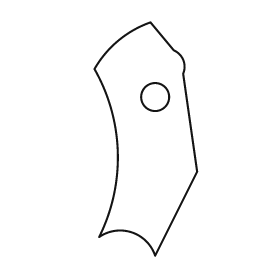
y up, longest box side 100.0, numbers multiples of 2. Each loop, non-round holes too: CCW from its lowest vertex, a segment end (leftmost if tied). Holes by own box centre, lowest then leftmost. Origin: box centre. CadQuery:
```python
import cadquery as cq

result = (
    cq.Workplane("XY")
    .moveTo(4.0, -50.0)
    .lineTo(22.0, -14.0)
    .lineTo(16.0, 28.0)
    .threePointArc((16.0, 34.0), (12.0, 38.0))
    .lineTo(2.0, 50.0)
    .threePointArc((-12.0, 42.0), (-22.0, 30.0))
    .threePointArc((-12.0, -6.0), (-20.0, -42.0))
    .threePointArc((-6.0, -40.0), (4.0, -50.0))
    .close()
    .moveTo(4.0, 18.0)
    .circle(6.0)
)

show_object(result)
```